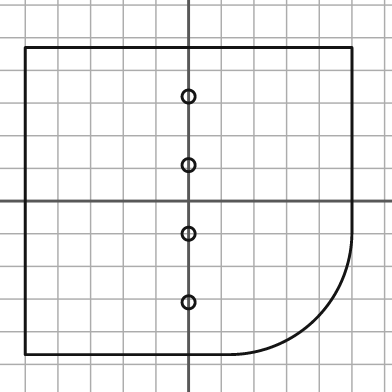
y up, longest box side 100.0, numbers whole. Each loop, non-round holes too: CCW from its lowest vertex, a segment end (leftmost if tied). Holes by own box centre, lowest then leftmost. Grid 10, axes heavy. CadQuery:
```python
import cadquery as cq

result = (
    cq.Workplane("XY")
    .moveTo(-50.0, -47.0)
    .lineTo(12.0, -47.0)
    .threePointArc((39.0, -36.0), (50.0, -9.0))
    .lineTo(50.0, 47.0)
    .lineTo(-50.0, 47.0)
    .close()
    .moveTo(0.0, -31.0)
    .circle(2.0)
    .moveTo(0.0, -10.0)
    .circle(2.0)
    .moveTo(0.0, 11.0)
    .circle(2.0)
    .moveTo(0.0, 32.0)
    .circle(2.0)
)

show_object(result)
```